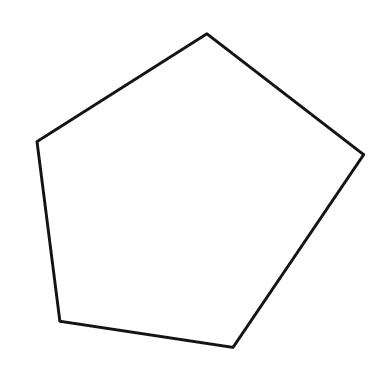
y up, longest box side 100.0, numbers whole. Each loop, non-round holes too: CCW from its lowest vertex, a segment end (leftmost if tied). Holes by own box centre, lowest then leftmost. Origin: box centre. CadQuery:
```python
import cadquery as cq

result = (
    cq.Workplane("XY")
    .moveTo(10.0, -48.0)
    .lineTo(50.0, 11.0)
    .lineTo(2.0, 48.0)
    .lineTo(-50.0, 15.0)
    .lineTo(-43.0, -40.0)
    .close()
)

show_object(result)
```